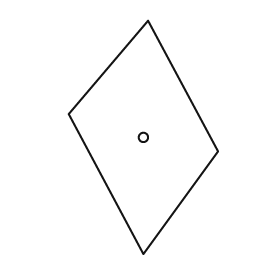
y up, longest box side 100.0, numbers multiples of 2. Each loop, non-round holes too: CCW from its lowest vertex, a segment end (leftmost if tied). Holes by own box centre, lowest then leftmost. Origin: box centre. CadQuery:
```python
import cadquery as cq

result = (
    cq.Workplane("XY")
    .moveTo(0.0, -50.0)
    .lineTo(32.0, -6.0)
    .lineTo(2.0, 50.0)
    .lineTo(-32.0, 10.0)
    .close()
    .moveTo(0.0, 0.0)
    .circle(2.0)
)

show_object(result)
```